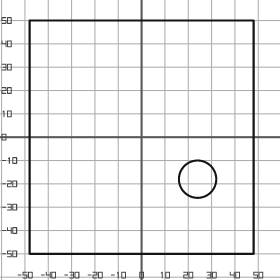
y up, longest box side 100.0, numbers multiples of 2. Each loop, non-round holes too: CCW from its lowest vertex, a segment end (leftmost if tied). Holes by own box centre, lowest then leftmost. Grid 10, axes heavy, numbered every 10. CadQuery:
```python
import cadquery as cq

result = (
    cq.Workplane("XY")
    .moveTo(-48.0, -50.0)
    .lineTo(48.0, -50.0)
    .lineTo(48.0, 50.0)
    .lineTo(-48.0, 50.0)
    .close()
    .moveTo(24.0, -18.0)
    .circle(8.0)
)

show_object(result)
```